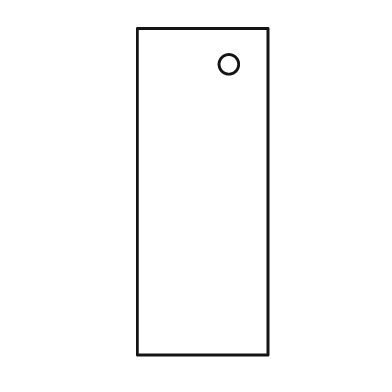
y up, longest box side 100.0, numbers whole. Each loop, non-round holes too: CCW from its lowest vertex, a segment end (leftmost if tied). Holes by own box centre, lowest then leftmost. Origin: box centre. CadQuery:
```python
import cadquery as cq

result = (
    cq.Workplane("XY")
    .moveTo(-20.0, -50.0)
    .lineTo(20.0, -50.0)
    .lineTo(20.0, 50.0)
    .lineTo(-20.0, 50.0)
    .close()
    .moveTo(8.0, 39.0)
    .circle(3.0)
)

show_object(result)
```